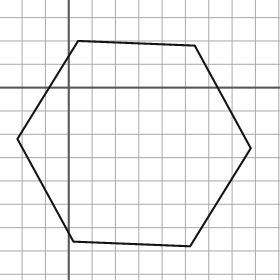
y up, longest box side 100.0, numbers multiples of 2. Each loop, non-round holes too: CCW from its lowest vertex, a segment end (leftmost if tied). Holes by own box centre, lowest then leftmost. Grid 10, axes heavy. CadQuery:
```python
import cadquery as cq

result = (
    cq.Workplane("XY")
    .moveTo(52.0, -68.0)
    .lineTo(78.0, -26.0)
    .lineTo(54.0, 18.0)
    .lineTo(4.0, 20.0)
    .lineTo(-22.0, -22.0)
    .lineTo(2.0, -66.0)
    .close()
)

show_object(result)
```